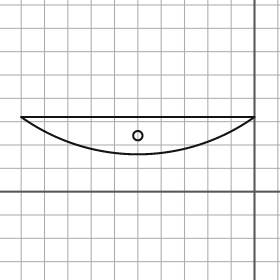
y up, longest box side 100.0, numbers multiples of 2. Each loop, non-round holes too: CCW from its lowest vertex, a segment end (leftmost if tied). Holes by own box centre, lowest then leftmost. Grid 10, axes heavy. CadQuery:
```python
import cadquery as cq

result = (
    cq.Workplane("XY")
    .moveTo(-100.0, 32.0)
    .threePointArc((-50.0, 16.0), (0.0, 32.0))
    .close()
    .moveTo(-50.0, 24.0)
    .circle(2.0)
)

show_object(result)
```